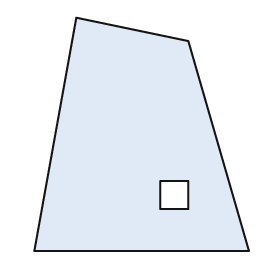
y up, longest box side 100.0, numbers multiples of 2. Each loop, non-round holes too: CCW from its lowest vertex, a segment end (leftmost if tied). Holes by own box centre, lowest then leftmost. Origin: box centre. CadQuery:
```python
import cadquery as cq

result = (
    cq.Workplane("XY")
    .moveTo(-46.0, -50.0)
    .lineTo(46.0, -50.0)
    .lineTo(20.0, 40.0)
    .lineTo(-28.0, 50.0)
    .close()
    .moveTo(8.0, -32.0)
    .lineTo(20.0, -32.0)
    .lineTo(20.0, -20.0)
    .lineTo(8.0, -20.0)
    .close()
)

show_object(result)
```